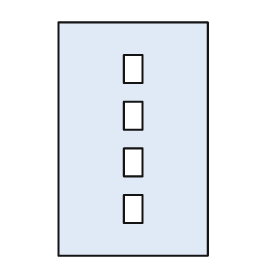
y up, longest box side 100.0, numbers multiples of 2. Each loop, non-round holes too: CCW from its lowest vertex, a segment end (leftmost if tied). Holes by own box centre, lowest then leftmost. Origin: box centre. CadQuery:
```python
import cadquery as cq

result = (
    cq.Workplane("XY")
    .moveTo(-32.0, -50.0)
    .lineTo(32.0, -50.0)
    .lineTo(32.0, 50.0)
    .lineTo(-32.0, 50.0)
    .close()
    .moveTo(-4.0, -36.0)
    .lineTo(4.0, -36.0)
    .lineTo(4.0, -24.0)
    .lineTo(-4.0, -24.0)
    .close()
    .moveTo(-4.0, -16.0)
    .lineTo(4.0, -16.0)
    .lineTo(4.0, -4.0)
    .lineTo(-4.0, -4.0)
    .close()
    .moveTo(-4.0, 4.0)
    .lineTo(4.0, 4.0)
    .lineTo(4.0, 16.0)
    .lineTo(-4.0, 16.0)
    .close()
    .moveTo(-4.0, 24.0)
    .lineTo(4.0, 24.0)
    .lineTo(4.0, 36.0)
    .lineTo(-4.0, 36.0)
    .close()
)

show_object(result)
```